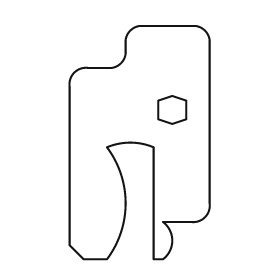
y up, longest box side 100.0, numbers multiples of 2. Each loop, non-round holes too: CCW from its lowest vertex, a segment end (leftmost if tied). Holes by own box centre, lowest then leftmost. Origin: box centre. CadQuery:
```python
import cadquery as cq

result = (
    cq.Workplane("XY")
    .moveTo(-24.0, -50.0)
    .lineTo(-14.0, -50.0)
    .threePointArc((-6.0, -26.0), (-14.0, -2.0))
    .threePointArc((-4.0, 0.0), (6.0, -2.0))
    .lineTo(6.0, -50.0)
    .lineTo(10.0, -50.0)
    .threePointArc((14.0, -42.0), (10.0, -34.0))
    .lineTo(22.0, -34.0)
    .threePointArc((28.0, -32.0), (30.0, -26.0))
    .lineTo(30.0, 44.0)
    .threePointArc((28.0, 48.0), (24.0, 50.0))
    .lineTo(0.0, 50.0)
    .threePointArc((-4.0, 48.0), (-6.0, 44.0))
    .lineTo(-6.0, 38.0)
    .threePointArc((-8.0, 34.0), (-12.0, 32.0))
    .lineTo(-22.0, 32.0)
    .threePointArc((-28.0, 30.0), (-30.0, 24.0))
    .lineTo(-30.0, -44.0)
    .close()
    .moveTo(14.0, 8.0)
    .lineTo(20.0, 10.0)
    .lineTo(20.0, 18.0)
    .lineTo(14.0, 20.0)
    .lineTo(8.0, 18.0)
    .lineTo(8.0, 10.0)
    .close()
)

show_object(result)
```